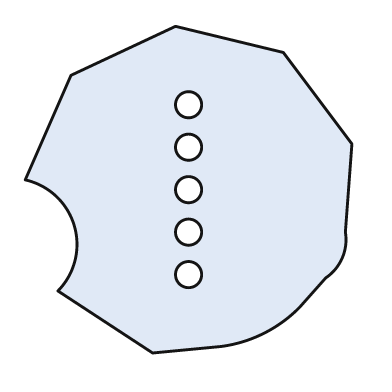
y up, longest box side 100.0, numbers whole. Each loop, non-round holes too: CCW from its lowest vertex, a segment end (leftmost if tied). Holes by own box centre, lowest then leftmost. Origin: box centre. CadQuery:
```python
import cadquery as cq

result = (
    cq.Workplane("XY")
    .moveTo(-11.0, -50.0)
    .lineTo(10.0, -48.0)
    .threePointArc((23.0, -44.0), (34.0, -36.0))
    .lineTo(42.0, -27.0)
    .threePointArc((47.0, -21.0), (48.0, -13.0))
    .lineTo(50.0, 14.0)
    .lineTo(29.0, 42.0)
    .lineTo(-4.0, 50.0)
    .lineTo(-36.0, 35.0)
    .lineTo(-50.0, 3.0)
    .threePointArc((-35.0, -11.0), (-40.0, -31.0))
    .close()
    .moveTo(0.0, -26.0)
    .circle(4.0)
    .moveTo(0.0, -13.0)
    .circle(4.0)
    .moveTo(0.0, 0.0)
    .circle(4.0)
    .moveTo(0.0, 13.0)
    .circle(4.0)
    .moveTo(0.0, 26.0)
    .circle(4.0)
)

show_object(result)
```